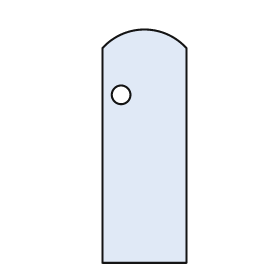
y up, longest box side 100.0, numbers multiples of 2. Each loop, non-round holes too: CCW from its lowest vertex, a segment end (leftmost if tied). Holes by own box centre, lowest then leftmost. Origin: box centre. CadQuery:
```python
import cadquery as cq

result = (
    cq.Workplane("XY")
    .moveTo(-18.0, -50.0)
    .lineTo(18.0, -50.0)
    .lineTo(18.0, 42.0)
    .threePointArc((0.0, 50.0), (-18.0, 42.0))
    .close()
    .moveTo(-10.0, 22.0)
    .circle(4.0)
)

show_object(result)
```